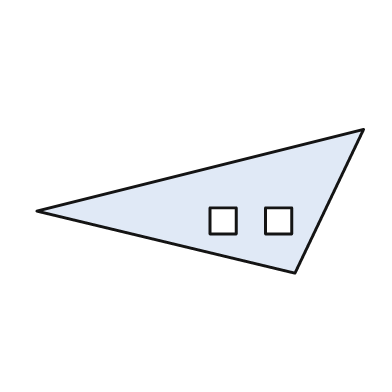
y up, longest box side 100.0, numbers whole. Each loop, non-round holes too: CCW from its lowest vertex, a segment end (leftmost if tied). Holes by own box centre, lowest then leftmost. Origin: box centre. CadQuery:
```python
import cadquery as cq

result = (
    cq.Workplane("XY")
    .moveTo(29.0, -22.0)
    .lineTo(50.0, 22.0)
    .lineTo(-50.0, -3.0)
    .close()
    .moveTo(3.0, -10.0)
    .lineTo(11.0, -10.0)
    .lineTo(11.0, -2.0)
    .lineTo(3.0, -2.0)
    .close()
    .moveTo(20.0, -10.0)
    .lineTo(28.0, -10.0)
    .lineTo(28.0, -2.0)
    .lineTo(20.0, -2.0)
    .close()
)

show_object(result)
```